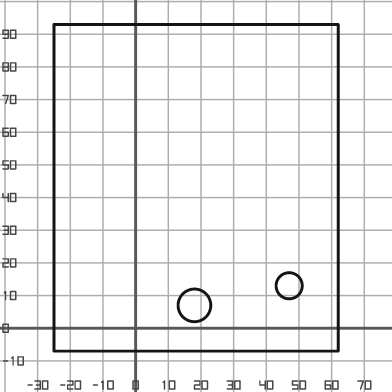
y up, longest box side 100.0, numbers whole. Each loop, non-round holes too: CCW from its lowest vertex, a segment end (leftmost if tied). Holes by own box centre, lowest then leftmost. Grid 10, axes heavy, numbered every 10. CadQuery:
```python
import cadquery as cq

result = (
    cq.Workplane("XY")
    .moveTo(-25.0, -7.0)
    .lineTo(62.0, -7.0)
    .lineTo(62.0, 93.0)
    .lineTo(-25.0, 93.0)
    .close()
    .moveTo(18.0, 7.0)
    .circle(5.0)
    .moveTo(47.0, 13.0)
    .circle(4.0)
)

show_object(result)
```